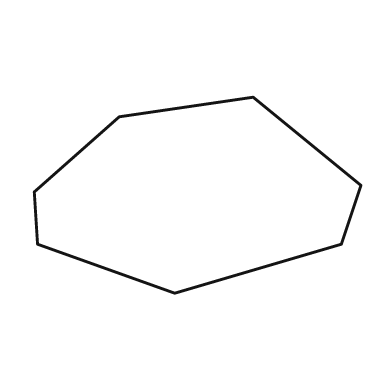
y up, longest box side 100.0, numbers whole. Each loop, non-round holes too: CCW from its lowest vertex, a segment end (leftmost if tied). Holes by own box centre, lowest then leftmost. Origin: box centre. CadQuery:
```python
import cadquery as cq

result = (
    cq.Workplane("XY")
    .moveTo(-7.0, -30.0)
    .lineTo(44.0, -15.0)
    .lineTo(50.0, 3.0)
    .lineTo(17.0, 30.0)
    .lineTo(-24.0, 24.0)
    .lineTo(-50.0, 1.0)
    .lineTo(-49.0, -15.0)
    .close()
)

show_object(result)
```